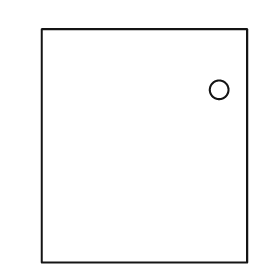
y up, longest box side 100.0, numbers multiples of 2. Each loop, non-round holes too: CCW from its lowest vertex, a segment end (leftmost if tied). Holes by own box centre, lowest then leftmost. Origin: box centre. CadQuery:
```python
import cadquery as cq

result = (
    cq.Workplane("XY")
    .moveTo(-44.0, -50.0)
    .lineTo(44.0, -50.0)
    .lineTo(44.0, 50.0)
    .lineTo(-44.0, 50.0)
    .close()
    .moveTo(32.0, 24.0)
    .circle(4.0)
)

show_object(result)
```